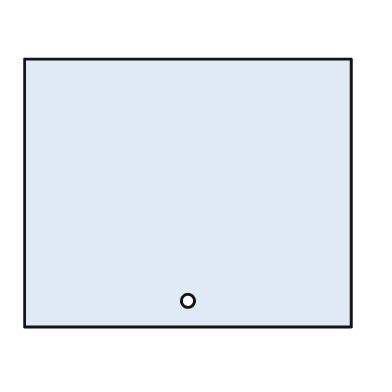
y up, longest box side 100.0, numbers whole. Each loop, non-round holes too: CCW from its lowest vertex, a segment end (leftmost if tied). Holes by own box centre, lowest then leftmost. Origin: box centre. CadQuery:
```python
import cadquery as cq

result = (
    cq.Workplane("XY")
    .moveTo(-50.0, -41.0)
    .lineTo(50.0, -41.0)
    .lineTo(50.0, 41.0)
    .lineTo(-50.0, 41.0)
    .close()
    .moveTo(0.0, -33.0)
    .circle(2.0)
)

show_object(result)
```